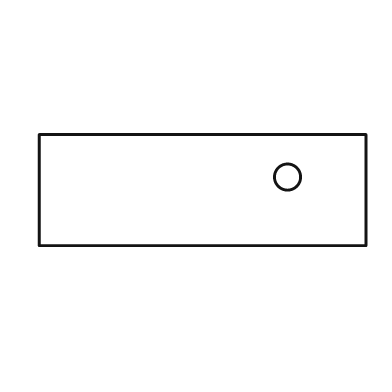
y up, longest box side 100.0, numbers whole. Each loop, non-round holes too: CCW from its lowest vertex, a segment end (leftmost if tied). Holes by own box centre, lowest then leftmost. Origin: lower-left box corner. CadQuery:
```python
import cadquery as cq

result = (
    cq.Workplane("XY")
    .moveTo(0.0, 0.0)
    .lineTo(100.0, 0.0)
    .lineTo(100.0, 34.0)
    .lineTo(0.0, 34.0)
    .close()
    .moveTo(76.0, 21.0)
    .circle(4.0)
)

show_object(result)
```